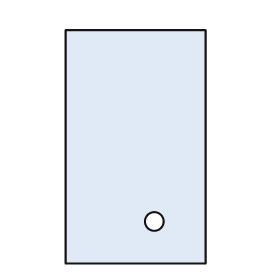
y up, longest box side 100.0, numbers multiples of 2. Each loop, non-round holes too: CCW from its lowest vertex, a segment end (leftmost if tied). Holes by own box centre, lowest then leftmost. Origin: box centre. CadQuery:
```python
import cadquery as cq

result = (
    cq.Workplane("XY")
    .moveTo(-30.0, -50.0)
    .lineTo(30.0, -50.0)
    .lineTo(30.0, 50.0)
    .lineTo(-30.0, 50.0)
    .close()
    .moveTo(8.0, -32.0)
    .circle(4.0)
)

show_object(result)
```